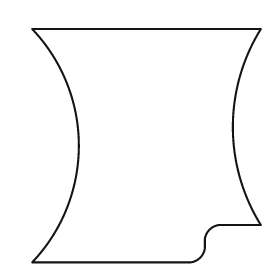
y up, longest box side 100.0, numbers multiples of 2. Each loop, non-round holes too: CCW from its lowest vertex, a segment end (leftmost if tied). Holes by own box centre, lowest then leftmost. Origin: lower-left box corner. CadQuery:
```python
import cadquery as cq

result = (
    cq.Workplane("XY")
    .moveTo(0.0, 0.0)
    .lineTo(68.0, 0.0)
    .threePointArc((72.0, 2.0), (74.0, 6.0))
    .lineTo(74.0, 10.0)
    .threePointArc((76.0, 14.0), (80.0, 16.0))
    .lineTo(98.0, 16.0)
    .threePointArc((86.0, 58.0), (98.0, 100.0))
    .lineTo(0.0, 100.0)
    .threePointArc((20.0, 50.0), (0.0, 0.0))
    .close()
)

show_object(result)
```